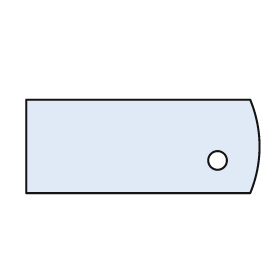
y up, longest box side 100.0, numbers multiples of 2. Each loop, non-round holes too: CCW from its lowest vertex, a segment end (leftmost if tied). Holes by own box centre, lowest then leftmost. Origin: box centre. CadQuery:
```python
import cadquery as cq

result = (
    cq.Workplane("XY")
    .moveTo(-50.0, -20.0)
    .lineTo(46.0, -20.0)
    .threePointArc((50.0, 0.0), (46.0, 20.0))
    .lineTo(-50.0, 20.0)
    .close()
    .moveTo(32.0, -6.0)
    .circle(4.0)
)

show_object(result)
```